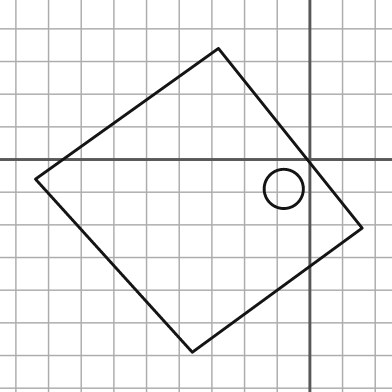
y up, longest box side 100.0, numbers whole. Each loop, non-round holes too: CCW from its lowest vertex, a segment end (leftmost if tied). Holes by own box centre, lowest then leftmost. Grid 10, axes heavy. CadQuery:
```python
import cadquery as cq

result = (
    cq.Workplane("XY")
    .moveTo(-36.0, -59.0)
    .lineTo(16.0, -21.0)
    .lineTo(-28.0, 34.0)
    .lineTo(-84.0, -6.0)
    .close()
    .moveTo(-8.0, -9.0)
    .circle(6.0)
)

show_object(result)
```